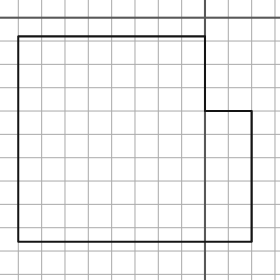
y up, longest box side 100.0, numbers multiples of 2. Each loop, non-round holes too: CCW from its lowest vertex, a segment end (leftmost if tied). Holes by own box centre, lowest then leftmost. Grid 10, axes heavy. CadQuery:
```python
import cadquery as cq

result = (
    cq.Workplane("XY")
    .moveTo(-80.0, -96.0)
    .lineTo(20.0, -96.0)
    .lineTo(20.0, -40.0)
    .lineTo(0.0, -40.0)
    .lineTo(0.0, -8.0)
    .lineTo(-80.0, -8.0)
    .close()
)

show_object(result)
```